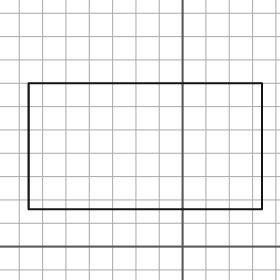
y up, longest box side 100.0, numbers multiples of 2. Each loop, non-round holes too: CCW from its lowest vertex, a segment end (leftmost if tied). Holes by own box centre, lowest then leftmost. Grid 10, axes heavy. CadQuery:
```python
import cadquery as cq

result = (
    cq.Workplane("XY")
    .moveTo(-66.0, 16.0)
    .lineTo(34.0, 16.0)
    .lineTo(34.0, 70.0)
    .lineTo(-66.0, 70.0)
    .close()
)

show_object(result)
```